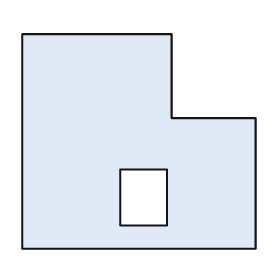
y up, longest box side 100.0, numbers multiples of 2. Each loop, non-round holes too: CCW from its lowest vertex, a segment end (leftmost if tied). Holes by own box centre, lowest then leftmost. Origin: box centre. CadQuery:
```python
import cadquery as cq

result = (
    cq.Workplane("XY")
    .moveTo(-50.0, -46.0)
    .lineTo(50.0, -46.0)
    .lineTo(50.0, 10.0)
    .lineTo(14.0, 10.0)
    .lineTo(14.0, 46.0)
    .lineTo(-50.0, 46.0)
    .close()
    .moveTo(-8.0, -36.0)
    .lineTo(12.0, -36.0)
    .lineTo(12.0, -12.0)
    .lineTo(-8.0, -12.0)
    .close()
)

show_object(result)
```